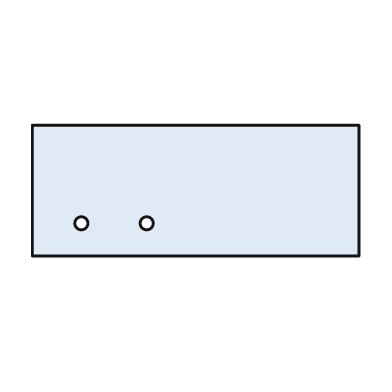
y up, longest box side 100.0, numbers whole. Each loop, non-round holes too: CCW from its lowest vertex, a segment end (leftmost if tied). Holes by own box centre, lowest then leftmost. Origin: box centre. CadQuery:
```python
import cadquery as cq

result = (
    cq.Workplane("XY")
    .moveTo(-50.0, -20.0)
    .lineTo(50.0, -20.0)
    .lineTo(50.0, 20.0)
    .lineTo(-50.0, 20.0)
    .close()
    .moveTo(-35.0, -10.0)
    .circle(2.0)
    .moveTo(-15.0, -10.0)
    .circle(2.0)
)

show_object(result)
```